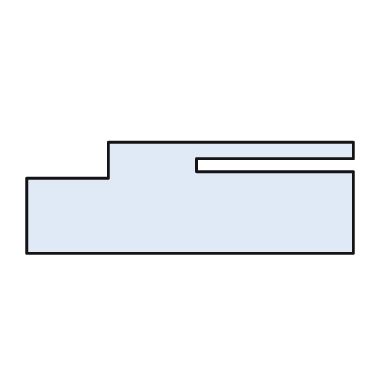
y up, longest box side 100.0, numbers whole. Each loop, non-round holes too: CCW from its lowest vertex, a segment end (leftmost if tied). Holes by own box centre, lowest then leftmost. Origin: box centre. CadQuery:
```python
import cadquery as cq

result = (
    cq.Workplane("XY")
    .moveTo(-50.0, -17.0)
    .lineTo(50.0, -17.0)
    .lineTo(50.0, 8.0)
    .lineTo(2.0, 8.0)
    .lineTo(2.0, 12.0)
    .lineTo(50.0, 12.0)
    .lineTo(50.0, 17.0)
    .lineTo(-25.0, 17.0)
    .lineTo(-25.0, 6.0)
    .lineTo(-50.0, 6.0)
    .close()
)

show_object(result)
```